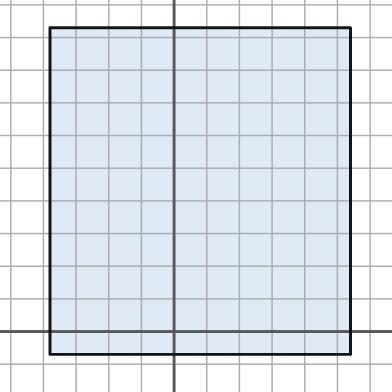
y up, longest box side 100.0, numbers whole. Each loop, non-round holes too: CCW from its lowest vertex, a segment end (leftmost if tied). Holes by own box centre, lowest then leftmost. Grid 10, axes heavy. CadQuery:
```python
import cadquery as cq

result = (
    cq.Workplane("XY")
    .moveTo(-38.0, -7.0)
    .lineTo(54.0, -7.0)
    .lineTo(54.0, 93.0)
    .lineTo(-38.0, 93.0)
    .close()
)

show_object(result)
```